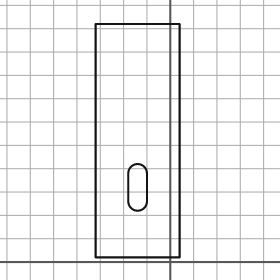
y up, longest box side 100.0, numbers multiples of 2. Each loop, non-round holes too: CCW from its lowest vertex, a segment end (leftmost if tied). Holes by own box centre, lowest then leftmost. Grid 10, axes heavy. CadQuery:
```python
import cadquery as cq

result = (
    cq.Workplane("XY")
    .moveTo(-32.0, 2.0)
    .lineTo(4.0, 2.0)
    .lineTo(4.0, 102.0)
    .lineTo(-32.0, 102.0)
    .close()
    .moveTo(-18.0, 26.0)
    .threePointArc((-14.0, 22.0), (-10.0, 26.0))
    .lineTo(-10.0, 38.0)
    .threePointArc((-14.0, 42.0), (-18.0, 38.0))
    .close()
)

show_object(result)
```